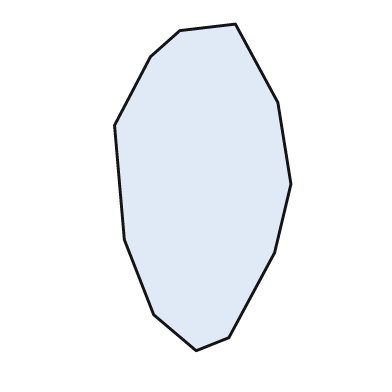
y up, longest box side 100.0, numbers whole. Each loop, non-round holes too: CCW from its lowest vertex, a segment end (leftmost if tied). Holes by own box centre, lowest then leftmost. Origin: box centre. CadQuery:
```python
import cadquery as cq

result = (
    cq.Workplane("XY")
    .moveTo(-2.0, -50.0)
    .lineTo(8.0, -46.0)
    .lineTo(22.0, -20.0)
    .lineTo(27.0, 1.0)
    .lineTo(23.0, 26.0)
    .lineTo(10.0, 50.0)
    .lineTo(-7.0, 48.0)
    .lineTo(-16.0, 40.0)
    .lineTo(-27.0, 19.0)
    .lineTo(-24.0, -16.0)
    .lineTo(-15.0, -39.0)
    .close()
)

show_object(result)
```